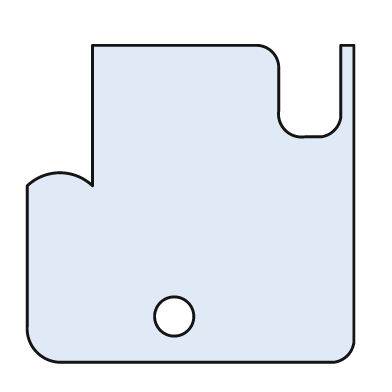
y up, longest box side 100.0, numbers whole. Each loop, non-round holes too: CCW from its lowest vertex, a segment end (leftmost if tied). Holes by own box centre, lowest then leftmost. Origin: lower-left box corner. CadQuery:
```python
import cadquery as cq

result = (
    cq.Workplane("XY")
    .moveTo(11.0, 0.0)
    .lineTo(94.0, 0.0)
    .threePointArc((98.0, 2.0), (100.0, 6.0))
    .lineTo(100.0, 97.0)
    .lineTo(96.0, 97.0)
    .lineTo(96.0, 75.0)
    .threePointArc((94.0, 71.0), (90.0, 69.0))
    .lineTo(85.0, 69.0)
    .threePointArc((79.0, 71.0), (77.0, 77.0))
    .lineTo(77.0, 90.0)
    .threePointArc((75.0, 95.0), (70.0, 97.0))
    .lineTo(20.0, 97.0)
    .lineTo(20.0, 54.0)
    .threePointArc((10.0, 58.0), (0.0, 54.0))
    .lineTo(0.0, 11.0)
    .threePointArc((3.0, 3.0), (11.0, 0.0))
    .close()
    .moveTo(45.0, 14.0)
    .circle(6.0)
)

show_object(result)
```